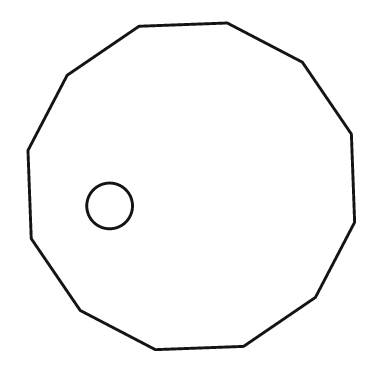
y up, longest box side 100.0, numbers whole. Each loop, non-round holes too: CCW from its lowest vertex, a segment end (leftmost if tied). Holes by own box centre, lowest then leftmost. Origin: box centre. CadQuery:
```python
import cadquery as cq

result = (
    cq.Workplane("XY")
    .moveTo(-11.0, -50.0)
    .lineTo(16.0, -49.0)
    .lineTo(38.0, -34.0)
    .lineTo(50.0, -11.0)
    .lineTo(49.0, 16.0)
    .lineTo(34.0, 38.0)
    .lineTo(11.0, 50.0)
    .lineTo(-16.0, 49.0)
    .lineTo(-38.0, 34.0)
    .lineTo(-50.0, 11.0)
    .lineTo(-49.0, -16.0)
    .lineTo(-34.0, -38.0)
    .close()
    .moveTo(-25.0, -6.0)
    .circle(7.0)
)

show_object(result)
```